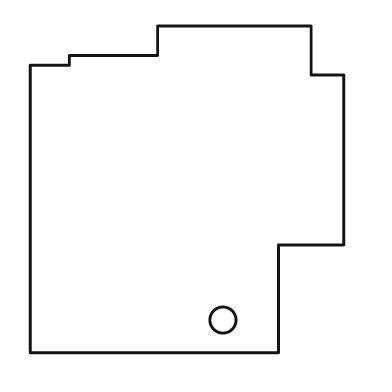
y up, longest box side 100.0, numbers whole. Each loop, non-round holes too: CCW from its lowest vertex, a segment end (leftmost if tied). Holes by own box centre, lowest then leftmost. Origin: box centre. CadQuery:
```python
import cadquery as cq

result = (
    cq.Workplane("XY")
    .moveTo(-48.0, -50.0)
    .lineTo(28.0, -50.0)
    .lineTo(28.0, -17.0)
    .lineTo(48.0, -17.0)
    .lineTo(48.0, 35.0)
    .lineTo(38.0, 35.0)
    .lineTo(38.0, 50.0)
    .lineTo(-9.0, 50.0)
    .lineTo(-9.0, 41.0)
    .lineTo(-36.0, 41.0)
    .lineTo(-36.0, 38.0)
    .lineTo(-48.0, 38.0)
    .close()
    .moveTo(11.0, -40.0)
    .circle(4.0)
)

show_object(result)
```